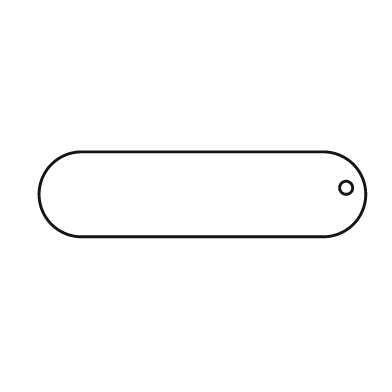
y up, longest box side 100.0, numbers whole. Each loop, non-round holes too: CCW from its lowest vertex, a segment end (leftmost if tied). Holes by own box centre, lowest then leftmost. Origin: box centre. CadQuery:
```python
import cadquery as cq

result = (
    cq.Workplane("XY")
    .moveTo(-37.0, -13.0)
    .lineTo(37.0, -13.0)
    .threePointArc((50.0, 0.0), (37.0, 13.0))
    .lineTo(-37.0, 13.0)
    .threePointArc((-50.0, 0.0), (-37.0, -13.0))
    .close()
    .moveTo(44.0, 2.0)
    .circle(2.0)
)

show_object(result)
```